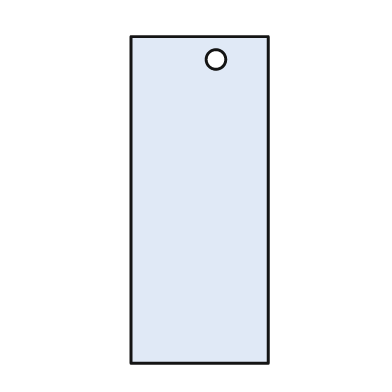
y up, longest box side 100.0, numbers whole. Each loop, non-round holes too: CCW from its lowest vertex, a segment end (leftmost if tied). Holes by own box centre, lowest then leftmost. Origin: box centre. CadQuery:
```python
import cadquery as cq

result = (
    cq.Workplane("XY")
    .moveTo(-21.0, -50.0)
    .lineTo(21.0, -50.0)
    .lineTo(21.0, 50.0)
    .lineTo(-21.0, 50.0)
    .close()
    .moveTo(5.0, 43.0)
    .circle(3.0)
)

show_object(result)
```